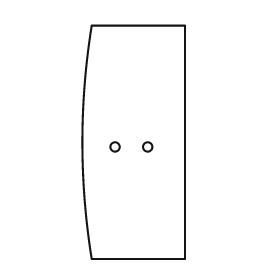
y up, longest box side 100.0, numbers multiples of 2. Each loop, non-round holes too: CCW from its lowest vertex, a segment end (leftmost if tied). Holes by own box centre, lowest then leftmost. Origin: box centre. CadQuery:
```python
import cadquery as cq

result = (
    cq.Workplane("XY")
    .moveTo(-18.0, -50.0)
    .lineTo(22.0, -50.0)
    .lineTo(22.0, 50.0)
    .lineTo(-18.0, 50.0)
    .threePointArc((-22.0, 0.0), (-18.0, -50.0))
    .close()
    .moveTo(-8.0, -2.0)
    .circle(2.0)
    .moveTo(6.0, -2.0)
    .circle(2.0)
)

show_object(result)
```